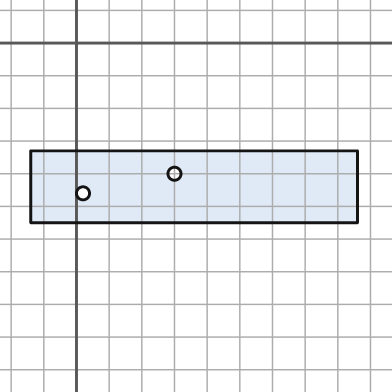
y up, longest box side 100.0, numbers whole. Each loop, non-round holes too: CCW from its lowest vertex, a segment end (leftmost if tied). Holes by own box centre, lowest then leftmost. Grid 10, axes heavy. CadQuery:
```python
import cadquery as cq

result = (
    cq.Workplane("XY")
    .moveTo(-14.0, -55.0)
    .lineTo(86.0, -55.0)
    .lineTo(86.0, -33.0)
    .lineTo(-14.0, -33.0)
    .close()
    .moveTo(2.0, -46.0)
    .circle(2.0)
    .moveTo(30.0, -40.0)
    .circle(2.0)
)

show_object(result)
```